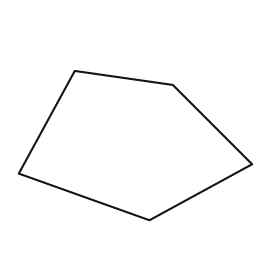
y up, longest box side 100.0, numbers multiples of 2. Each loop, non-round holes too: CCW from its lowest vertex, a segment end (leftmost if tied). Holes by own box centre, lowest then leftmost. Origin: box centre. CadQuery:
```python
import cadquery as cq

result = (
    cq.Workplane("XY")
    .moveTo(6.0, -32.0)
    .lineTo(50.0, -8.0)
    .lineTo(16.0, 26.0)
    .lineTo(-26.0, 32.0)
    .lineTo(-50.0, -12.0)
    .close()
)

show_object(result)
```